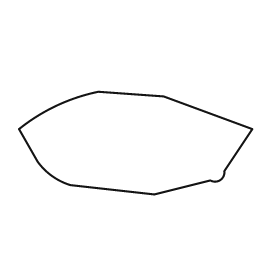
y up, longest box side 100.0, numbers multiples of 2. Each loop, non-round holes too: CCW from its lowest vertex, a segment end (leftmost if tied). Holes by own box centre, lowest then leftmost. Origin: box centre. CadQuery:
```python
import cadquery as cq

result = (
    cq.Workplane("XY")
    .moveTo(8.0, -22.0)
    .lineTo(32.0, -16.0)
    .threePointArc((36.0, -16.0), (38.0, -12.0))
    .lineTo(50.0, 6.0)
    .lineTo(12.0, 20.0)
    .lineTo(-16.0, 22.0)
    .threePointArc((-34.0, 16.0), (-50.0, 6.0))
    .lineTo(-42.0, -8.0)
    .threePointArc((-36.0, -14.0), (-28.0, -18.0))
    .close()
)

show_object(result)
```